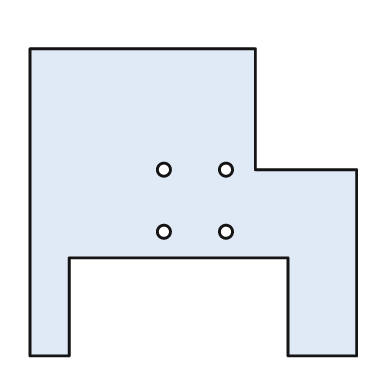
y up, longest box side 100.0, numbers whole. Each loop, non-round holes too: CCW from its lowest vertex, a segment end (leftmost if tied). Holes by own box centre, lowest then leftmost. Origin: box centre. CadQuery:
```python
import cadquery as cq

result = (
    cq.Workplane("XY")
    .moveTo(-50.0, -47.0)
    .lineTo(-38.0, -47.0)
    .lineTo(-38.0, -17.0)
    .lineTo(29.0, -17.0)
    .lineTo(29.0, -47.0)
    .lineTo(50.0, -47.0)
    .lineTo(50.0, 10.0)
    .lineTo(19.0, 10.0)
    .lineTo(19.0, 47.0)
    .lineTo(-50.0, 47.0)
    .close()
    .moveTo(-9.0, -9.0)
    .circle(2.0)
    .moveTo(10.0, -9.0)
    .circle(2.0)
    .moveTo(-9.0, 10.0)
    .circle(2.0)
    .moveTo(10.0, 10.0)
    .circle(2.0)
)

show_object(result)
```